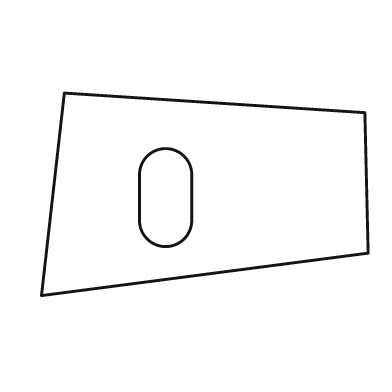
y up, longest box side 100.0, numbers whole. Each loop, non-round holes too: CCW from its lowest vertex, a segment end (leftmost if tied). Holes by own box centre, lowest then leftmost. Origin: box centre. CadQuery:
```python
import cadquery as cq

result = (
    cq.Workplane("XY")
    .moveTo(-50.0, -31.0)
    .lineTo(50.0, -18.0)
    .lineTo(49.0, 25.0)
    .lineTo(-43.0, 31.0)
    .close()
    .moveTo(-20.0, -8.0)
    .threePointArc((-12.0, -16.0), (-4.0, -8.0))
    .lineTo(-4.0, 6.0)
    .threePointArc((-12.0, 14.0), (-20.0, 6.0))
    .close()
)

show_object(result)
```